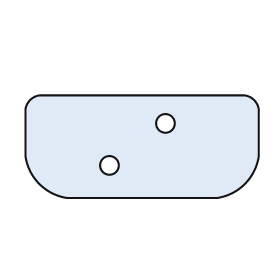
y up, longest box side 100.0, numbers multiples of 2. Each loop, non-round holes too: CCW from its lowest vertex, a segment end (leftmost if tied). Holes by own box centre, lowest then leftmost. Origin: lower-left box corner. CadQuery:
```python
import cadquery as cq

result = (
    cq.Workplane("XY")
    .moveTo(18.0, 0.0)
    .lineTo(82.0, 0.0)
    .threePointArc((94.0, 6.0), (100.0, 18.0))
    .lineTo(100.0, 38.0)
    .threePointArc((98.0, 42.0), (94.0, 44.0))
    .lineTo(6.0, 44.0)
    .threePointArc((2.0, 42.0), (0.0, 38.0))
    .lineTo(0.0, 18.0)
    .threePointArc((6.0, 6.0), (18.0, 0.0))
    .close()
    .moveTo(36.0, 14.0)
    .circle(4.0)
    .moveTo(60.0, 32.0)
    .circle(4.0)
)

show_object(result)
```